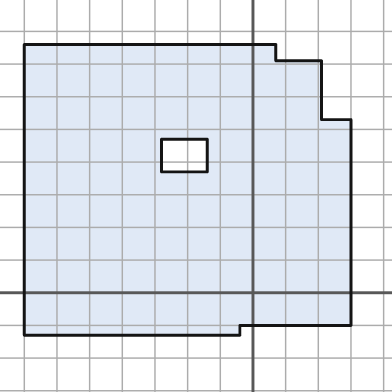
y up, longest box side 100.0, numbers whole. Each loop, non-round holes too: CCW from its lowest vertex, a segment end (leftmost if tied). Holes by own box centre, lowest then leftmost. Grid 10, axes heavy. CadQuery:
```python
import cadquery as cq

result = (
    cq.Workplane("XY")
    .moveTo(-70.0, -13.0)
    .lineTo(-4.0, -13.0)
    .lineTo(-4.0, -10.0)
    .lineTo(30.0, -10.0)
    .lineTo(30.0, 53.0)
    .lineTo(21.0, 53.0)
    .lineTo(21.0, 71.0)
    .lineTo(7.0, 71.0)
    .lineTo(7.0, 76.0)
    .lineTo(-70.0, 76.0)
    .close()
    .moveTo(-28.0, 37.0)
    .lineTo(-14.0, 37.0)
    .lineTo(-14.0, 47.0)
    .lineTo(-28.0, 47.0)
    .close()
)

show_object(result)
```